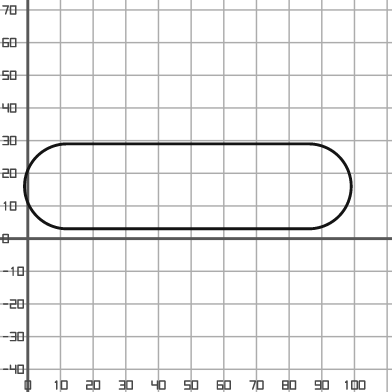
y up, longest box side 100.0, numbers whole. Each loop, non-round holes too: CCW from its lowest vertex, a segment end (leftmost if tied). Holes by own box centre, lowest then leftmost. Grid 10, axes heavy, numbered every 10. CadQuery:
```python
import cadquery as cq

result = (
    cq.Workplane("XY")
    .moveTo(12.0, 3.0)
    .lineTo(86.0, 3.0)
    .threePointArc((99.0, 16.0), (86.0, 29.0))
    .lineTo(12.0, 29.0)
    .threePointArc((-1.0, 16.0), (12.0, 3.0))
    .close()
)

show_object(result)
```